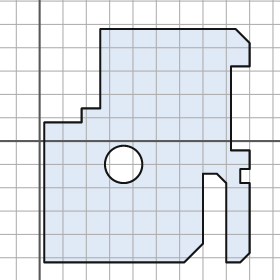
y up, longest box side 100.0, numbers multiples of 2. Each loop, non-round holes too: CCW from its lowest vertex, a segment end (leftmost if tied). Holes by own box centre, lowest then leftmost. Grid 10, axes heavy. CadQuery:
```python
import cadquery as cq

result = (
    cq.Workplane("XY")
    .moveTo(2.0, -52.0)
    .lineTo(62.0, -52.0)
    .lineTo(70.0, -44.0)
    .lineTo(70.0, -14.0)
    .lineTo(76.0, -14.0)
    .lineTo(80.0, -18.0)
    .lineTo(80.0, -52.0)
    .lineTo(86.0, -52.0)
    .lineTo(90.0, -48.0)
    .lineTo(90.0, -18.0)
    .lineTo(86.0, -18.0)
    .lineTo(86.0, -12.0)
    .lineTo(90.0, -12.0)
    .lineTo(90.0, -4.0)
    .lineTo(82.0, -4.0)
    .lineTo(82.0, 32.0)
    .lineTo(90.0, 32.0)
    .lineTo(90.0, 42.0)
    .lineTo(84.0, 48.0)
    .lineTo(26.0, 48.0)
    .lineTo(26.0, 14.0)
    .lineTo(18.0, 14.0)
    .lineTo(18.0, 8.0)
    .lineTo(2.0, 8.0)
    .close()
    .moveTo(36.0, -10.0)
    .circle(8.0)
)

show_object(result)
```